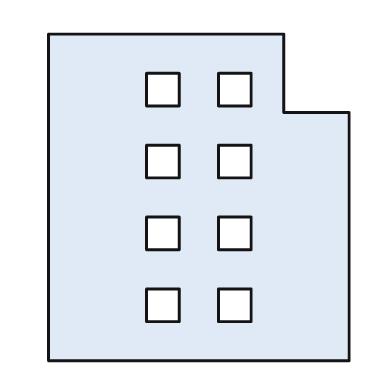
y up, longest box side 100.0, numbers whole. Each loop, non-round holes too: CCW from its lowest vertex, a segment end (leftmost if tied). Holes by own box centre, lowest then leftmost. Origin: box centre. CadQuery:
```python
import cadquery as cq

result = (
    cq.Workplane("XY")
    .moveTo(-46.0, -50.0)
    .lineTo(46.0, -50.0)
    .lineTo(46.0, 26.0)
    .lineTo(26.0, 26.0)
    .lineTo(26.0, 50.0)
    .lineTo(-46.0, 50.0)
    .close()
    .moveTo(-16.0, -38.0)
    .lineTo(-6.0, -38.0)
    .lineTo(-6.0, -28.0)
    .lineTo(-16.0, -28.0)
    .close()
    .moveTo(6.0, -38.0)
    .lineTo(16.0, -38.0)
    .lineTo(16.0, -28.0)
    .lineTo(6.0, -28.0)
    .close()
    .moveTo(-16.0, -16.0)
    .lineTo(-6.0, -16.0)
    .lineTo(-6.0, -6.0)
    .lineTo(-16.0, -6.0)
    .close()
    .moveTo(6.0, -16.0)
    .lineTo(16.0, -16.0)
    .lineTo(16.0, -6.0)
    .lineTo(6.0, -6.0)
    .close()
    .moveTo(-16.0, 6.0)
    .lineTo(-6.0, 6.0)
    .lineTo(-6.0, 16.0)
    .lineTo(-16.0, 16.0)
    .close()
    .moveTo(6.0, 6.0)
    .lineTo(16.0, 6.0)
    .lineTo(16.0, 16.0)
    .lineTo(6.0, 16.0)
    .close()
    .moveTo(-16.0, 28.0)
    .lineTo(-6.0, 28.0)
    .lineTo(-6.0, 38.0)
    .lineTo(-16.0, 38.0)
    .close()
    .moveTo(6.0, 28.0)
    .lineTo(16.0, 28.0)
    .lineTo(16.0, 38.0)
    .lineTo(6.0, 38.0)
    .close()
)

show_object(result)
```